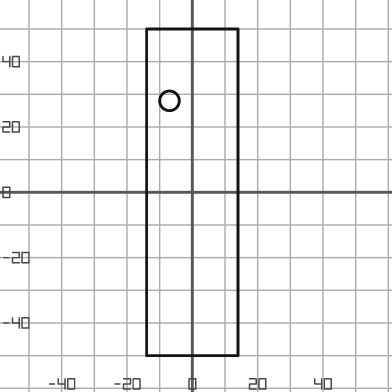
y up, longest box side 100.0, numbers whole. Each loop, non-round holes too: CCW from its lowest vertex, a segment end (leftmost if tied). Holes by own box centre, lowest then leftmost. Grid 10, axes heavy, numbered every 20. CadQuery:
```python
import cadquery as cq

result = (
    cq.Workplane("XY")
    .moveTo(-14.0, -50.0)
    .lineTo(14.0, -50.0)
    .lineTo(14.0, 50.0)
    .lineTo(-14.0, 50.0)
    .close()
    .moveTo(-7.0, 28.0)
    .circle(3.0)
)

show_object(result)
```